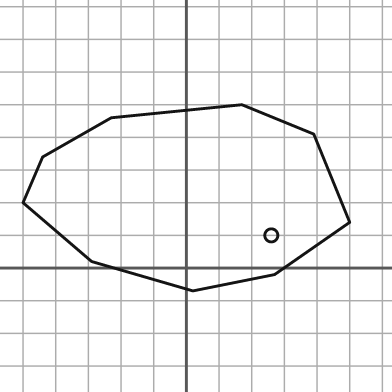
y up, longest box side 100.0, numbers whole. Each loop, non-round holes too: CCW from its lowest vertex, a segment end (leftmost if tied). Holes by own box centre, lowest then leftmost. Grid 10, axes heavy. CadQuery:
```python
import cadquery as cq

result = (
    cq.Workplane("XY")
    .moveTo(2.0, -7.0)
    .lineTo(27.0, -2.0)
    .lineTo(50.0, 14.0)
    .lineTo(39.0, 41.0)
    .lineTo(17.0, 50.0)
    .lineTo(-23.0, 46.0)
    .lineTo(-44.0, 34.0)
    .lineTo(-50.0, 20.0)
    .lineTo(-29.0, 2.0)
    .close()
    .moveTo(26.0, 10.0)
    .circle(2.0)
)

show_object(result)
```